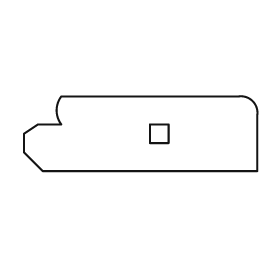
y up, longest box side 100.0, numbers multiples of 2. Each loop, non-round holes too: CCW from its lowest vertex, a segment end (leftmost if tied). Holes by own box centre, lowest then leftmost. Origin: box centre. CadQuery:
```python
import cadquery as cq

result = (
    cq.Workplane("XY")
    .moveTo(-42.0, -16.0)
    .lineTo(50.0, -16.0)
    .lineTo(50.0, 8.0)
    .threePointArc((48.0, 14.0), (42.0, 16.0))
    .lineTo(-34.0, 16.0)
    .threePointArc((-36.0, 10.0), (-34.0, 4.0))
    .lineTo(-44.0, 4.0)
    .lineTo(-50.0, 0.0)
    .lineTo(-50.0, -8.0)
    .close()
    .moveTo(4.0, -4.0)
    .lineTo(12.0, -4.0)
    .lineTo(12.0, 4.0)
    .lineTo(4.0, 4.0)
    .close()
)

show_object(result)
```